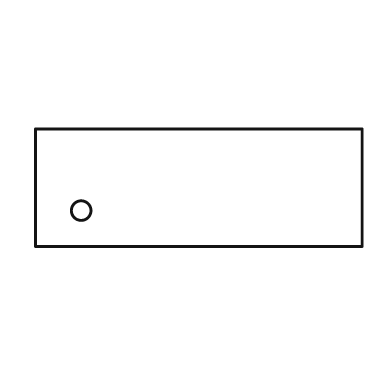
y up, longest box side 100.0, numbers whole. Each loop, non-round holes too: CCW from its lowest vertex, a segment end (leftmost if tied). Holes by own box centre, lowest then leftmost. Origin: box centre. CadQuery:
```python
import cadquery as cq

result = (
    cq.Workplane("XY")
    .moveTo(-50.0, -18.0)
    .lineTo(50.0, -18.0)
    .lineTo(50.0, 18.0)
    .lineTo(-50.0, 18.0)
    .close()
    .moveTo(-36.0, -7.0)
    .circle(3.0)
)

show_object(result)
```